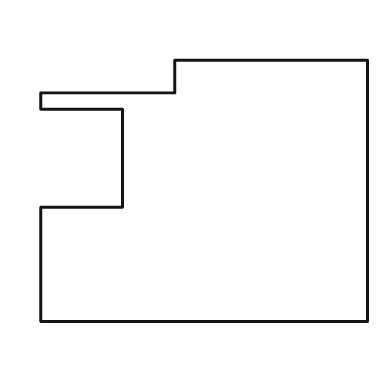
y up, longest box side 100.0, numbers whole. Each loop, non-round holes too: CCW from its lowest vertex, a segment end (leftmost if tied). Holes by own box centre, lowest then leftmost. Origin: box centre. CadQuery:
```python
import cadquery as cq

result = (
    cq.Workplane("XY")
    .moveTo(-50.0, -40.0)
    .lineTo(50.0, -40.0)
    .lineTo(50.0, 40.0)
    .lineTo(-9.0, 40.0)
    .lineTo(-9.0, 30.0)
    .lineTo(-50.0, 30.0)
    .lineTo(-50.0, 25.0)
    .lineTo(-25.0, 25.0)
    .lineTo(-25.0, -5.0)
    .lineTo(-50.0, -5.0)
    .close()
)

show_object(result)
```